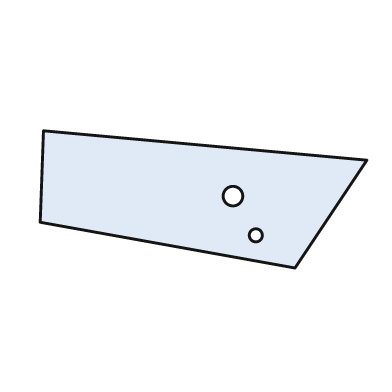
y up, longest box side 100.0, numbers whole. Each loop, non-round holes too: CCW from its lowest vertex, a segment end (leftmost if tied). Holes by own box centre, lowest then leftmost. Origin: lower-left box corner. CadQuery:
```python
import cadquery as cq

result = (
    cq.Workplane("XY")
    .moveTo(78.0, 0.0)
    .lineTo(100.0, 33.0)
    .lineTo(1.0, 42.0)
    .lineTo(0.0, 14.0)
    .close()
    .moveTo(66.0, 10.0)
    .circle(2.0)
    .moveTo(59.0, 22.0)
    .circle(3.0)
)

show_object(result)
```